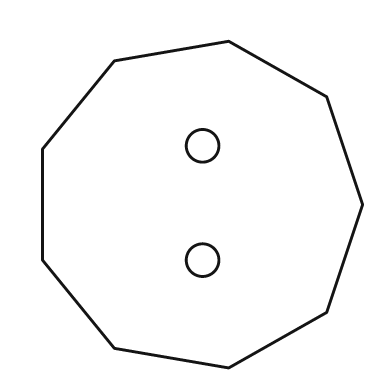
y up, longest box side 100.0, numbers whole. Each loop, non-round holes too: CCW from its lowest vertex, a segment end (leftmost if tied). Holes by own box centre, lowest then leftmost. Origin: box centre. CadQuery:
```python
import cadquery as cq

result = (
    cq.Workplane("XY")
    .moveTo(8.0, -50.0)
    .lineTo(38.0, -33.0)
    .lineTo(49.0, 0.0)
    .lineTo(38.0, 33.0)
    .lineTo(8.0, 50.0)
    .lineTo(-27.0, 44.0)
    .lineTo(-49.0, 17.0)
    .lineTo(-49.0, -17.0)
    .lineTo(-27.0, -44.0)
    .close()
    .moveTo(0.0, -17.0)
    .circle(5.0)
    .moveTo(0.0, 18.0)
    .circle(5.0)
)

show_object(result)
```